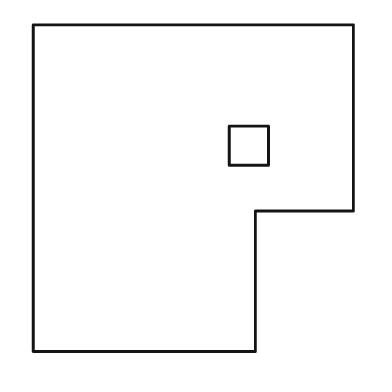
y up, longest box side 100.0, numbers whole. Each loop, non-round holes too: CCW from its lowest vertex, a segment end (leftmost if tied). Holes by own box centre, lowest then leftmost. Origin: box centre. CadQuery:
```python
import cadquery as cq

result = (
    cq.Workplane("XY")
    .moveTo(-49.0, -50.0)
    .lineTo(19.0, -50.0)
    .lineTo(19.0, -7.0)
    .lineTo(49.0, -7.0)
    .lineTo(49.0, 50.0)
    .lineTo(-49.0, 50.0)
    .close()
    .moveTo(11.0, 7.0)
    .lineTo(23.0, 7.0)
    .lineTo(23.0, 19.0)
    .lineTo(11.0, 19.0)
    .close()
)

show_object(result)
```